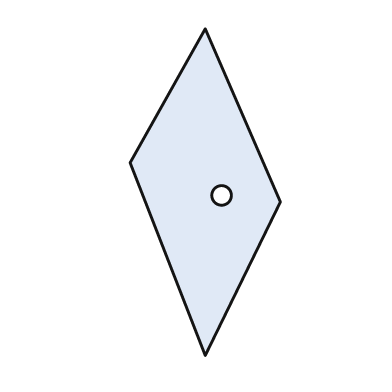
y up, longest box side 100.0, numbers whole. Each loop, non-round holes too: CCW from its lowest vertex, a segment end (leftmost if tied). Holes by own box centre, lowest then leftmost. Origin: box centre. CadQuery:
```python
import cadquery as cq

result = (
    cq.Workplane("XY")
    .moveTo(0.0, -50.0)
    .lineTo(23.0, -3.0)
    .lineTo(0.0, 50.0)
    .lineTo(-23.0, 9.0)
    .close()
    .moveTo(5.0, -1.0)
    .circle(3.0)
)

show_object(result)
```